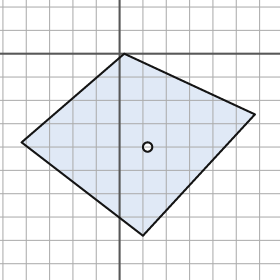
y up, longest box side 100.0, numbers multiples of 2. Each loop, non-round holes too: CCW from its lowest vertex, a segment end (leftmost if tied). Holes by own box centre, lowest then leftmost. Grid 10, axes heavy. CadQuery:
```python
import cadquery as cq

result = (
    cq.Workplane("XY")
    .moveTo(10.0, -78.0)
    .lineTo(58.0, -26.0)
    .lineTo(2.0, 0.0)
    .lineTo(-42.0, -38.0)
    .close()
    .moveTo(12.0, -40.0)
    .circle(2.0)
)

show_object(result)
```